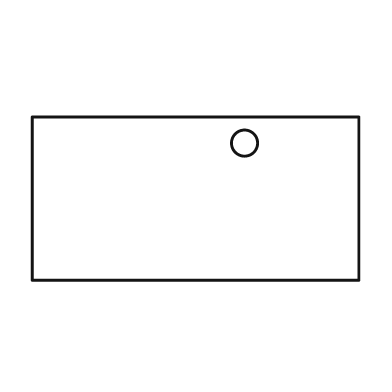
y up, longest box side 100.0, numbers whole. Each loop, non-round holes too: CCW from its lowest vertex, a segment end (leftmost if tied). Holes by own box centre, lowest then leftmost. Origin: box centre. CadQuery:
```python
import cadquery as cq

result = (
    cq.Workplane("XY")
    .moveTo(-50.0, -25.0)
    .lineTo(50.0, -25.0)
    .lineTo(50.0, 25.0)
    .lineTo(-50.0, 25.0)
    .close()
    .moveTo(15.0, 17.0)
    .circle(4.0)
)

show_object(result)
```